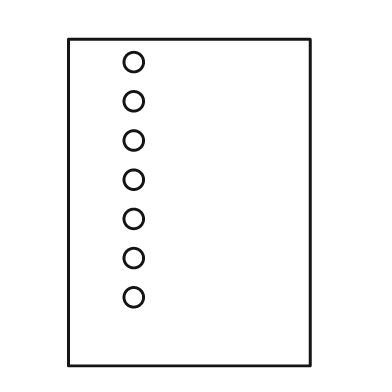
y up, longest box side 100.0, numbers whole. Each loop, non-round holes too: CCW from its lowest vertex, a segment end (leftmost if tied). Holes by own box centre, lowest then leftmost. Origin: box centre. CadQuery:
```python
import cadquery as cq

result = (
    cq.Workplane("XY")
    .moveTo(-37.0, -50.0)
    .lineTo(37.0, -50.0)
    .lineTo(37.0, 50.0)
    .lineTo(-37.0, 50.0)
    .close()
    .moveTo(-17.0, -29.0)
    .circle(3.0)
    .moveTo(-17.0, -17.0)
    .circle(3.0)
    .moveTo(-17.0, -5.0)
    .circle(3.0)
    .moveTo(-17.0, 7.0)
    .circle(3.0)
    .moveTo(-17.0, 19.0)
    .circle(3.0)
    .moveTo(-17.0, 31.0)
    .circle(3.0)
    .moveTo(-17.0, 43.0)
    .circle(3.0)
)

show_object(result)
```